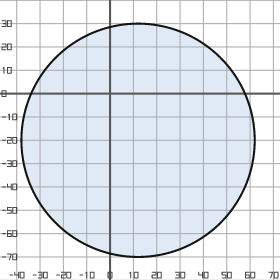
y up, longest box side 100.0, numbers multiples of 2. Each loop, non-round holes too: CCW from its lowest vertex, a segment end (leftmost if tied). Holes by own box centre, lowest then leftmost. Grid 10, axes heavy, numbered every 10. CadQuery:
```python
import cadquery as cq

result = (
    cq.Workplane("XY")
    .moveTo(12.0, -20.0)
    .circle(50.0)
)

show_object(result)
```